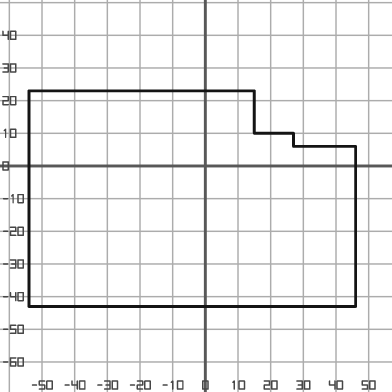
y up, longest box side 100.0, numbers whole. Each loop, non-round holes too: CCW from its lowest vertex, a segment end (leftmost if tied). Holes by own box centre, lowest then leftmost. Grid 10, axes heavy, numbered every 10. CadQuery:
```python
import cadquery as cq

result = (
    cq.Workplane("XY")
    .moveTo(-54.0, -43.0)
    .lineTo(46.0, -43.0)
    .lineTo(46.0, 6.0)
    .lineTo(27.0, 6.0)
    .lineTo(27.0, 10.0)
    .lineTo(15.0, 10.0)
    .lineTo(15.0, 23.0)
    .lineTo(-54.0, 23.0)
    .close()
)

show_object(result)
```